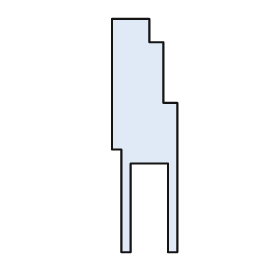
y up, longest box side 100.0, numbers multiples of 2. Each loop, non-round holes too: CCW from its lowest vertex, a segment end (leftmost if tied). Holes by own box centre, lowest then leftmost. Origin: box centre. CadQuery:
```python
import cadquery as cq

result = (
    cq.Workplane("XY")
    .moveTo(-10.0, -50.0)
    .lineTo(-6.0, -50.0)
    .lineTo(-6.0, -12.0)
    .lineTo(10.0, -12.0)
    .lineTo(10.0, -50.0)
    .lineTo(14.0, -50.0)
    .lineTo(14.0, 14.0)
    .lineTo(8.0, 14.0)
    .lineTo(8.0, 40.0)
    .lineTo(2.0, 40.0)
    .lineTo(2.0, 50.0)
    .lineTo(-14.0, 50.0)
    .lineTo(-14.0, -6.0)
    .lineTo(-10.0, -6.0)
    .close()
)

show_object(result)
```